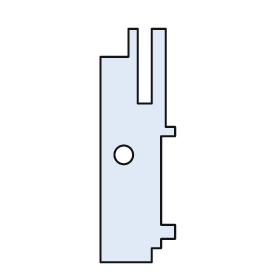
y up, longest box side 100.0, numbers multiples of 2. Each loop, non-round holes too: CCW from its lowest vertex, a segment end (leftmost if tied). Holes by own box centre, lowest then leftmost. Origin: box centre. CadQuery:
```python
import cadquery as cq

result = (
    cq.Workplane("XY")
    .moveTo(-16.0, -50.0)
    .lineTo(6.0, -50.0)
    .lineTo(6.0, -44.0)
    .lineTo(10.0, -44.0)
    .lineTo(10.0, -40.0)
    .lineTo(16.0, -40.0)
    .lineTo(16.0, -34.0)
    .lineTo(10.0, -34.0)
    .lineTo(10.0, 4.0)
    .lineTo(16.0, 4.0)
    .lineTo(16.0, 8.0)
    .lineTo(12.0, 8.0)
    .lineTo(12.0, 50.0)
    .lineTo(6.0, 50.0)
    .lineTo(6.0, 18.0)
    .lineTo(0.0, 18.0)
    .lineTo(0.0, 50.0)
    .lineTo(-4.0, 50.0)
    .lineTo(-4.0, 38.0)
    .lineTo(-16.0, 38.0)
    .close()
    .moveTo(-6.0, -4.0)
    .circle(4.0)
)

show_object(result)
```